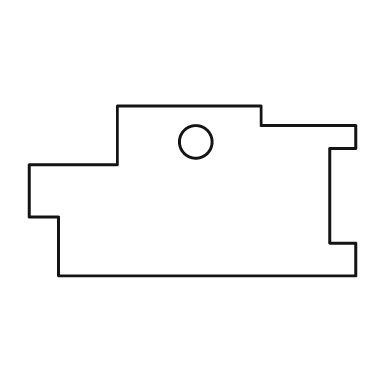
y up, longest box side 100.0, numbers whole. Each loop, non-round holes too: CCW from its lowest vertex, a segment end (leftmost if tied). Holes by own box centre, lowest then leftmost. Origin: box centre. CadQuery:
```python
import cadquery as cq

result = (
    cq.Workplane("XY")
    .moveTo(-41.0, -26.0)
    .lineTo(50.0, -26.0)
    .lineTo(50.0, -16.0)
    .lineTo(42.0, -16.0)
    .lineTo(42.0, 13.0)
    .lineTo(50.0, 13.0)
    .lineTo(50.0, 20.0)
    .lineTo(21.0, 20.0)
    .lineTo(21.0, 26.0)
    .lineTo(-23.0, 26.0)
    .lineTo(-23.0, 8.0)
    .lineTo(-50.0, 8.0)
    .lineTo(-50.0, -8.0)
    .lineTo(-41.0, -8.0)
    .close()
    .moveTo(1.0, 15.0)
    .circle(5.0)
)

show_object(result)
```